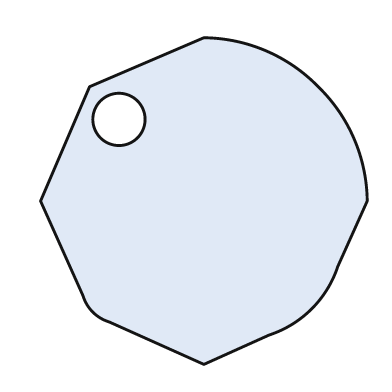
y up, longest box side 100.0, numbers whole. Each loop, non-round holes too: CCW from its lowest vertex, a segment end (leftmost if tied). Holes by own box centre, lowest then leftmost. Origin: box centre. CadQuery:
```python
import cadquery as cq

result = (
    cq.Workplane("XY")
    .moveTo(0.0, -50.0)
    .lineTo(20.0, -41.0)
    .threePointArc((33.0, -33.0), (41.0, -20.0))
    .lineTo(50.0, 0.0)
    .threePointArc((46.0, 19.0), (35.0, 35.0))
    .threePointArc((19.0, 46.0), (0.0, 50.0))
    .lineTo(-35.0, 35.0)
    .lineTo(-50.0, 0.0)
    .lineTo(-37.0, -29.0)
    .threePointArc((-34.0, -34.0), (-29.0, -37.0))
    .close()
    .moveTo(-26.0, 25.0)
    .circle(8.0)
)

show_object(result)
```